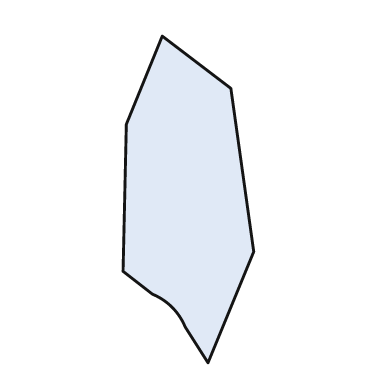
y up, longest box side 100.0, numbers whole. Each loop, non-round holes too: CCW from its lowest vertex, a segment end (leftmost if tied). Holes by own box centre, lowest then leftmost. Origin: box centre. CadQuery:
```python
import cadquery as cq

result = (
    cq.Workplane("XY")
    .moveTo(6.0, -50.0)
    .lineTo(20.0, -16.0)
    .lineTo(13.0, 34.0)
    .lineTo(-8.0, 50.0)
    .lineTo(-19.0, 23.0)
    .lineTo(-20.0, -22.0)
    .lineTo(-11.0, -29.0)
    .threePointArc((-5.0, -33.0), (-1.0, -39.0))
    .close()
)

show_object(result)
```